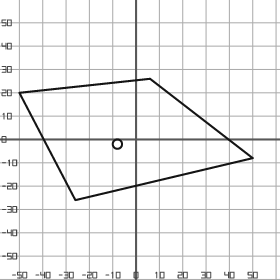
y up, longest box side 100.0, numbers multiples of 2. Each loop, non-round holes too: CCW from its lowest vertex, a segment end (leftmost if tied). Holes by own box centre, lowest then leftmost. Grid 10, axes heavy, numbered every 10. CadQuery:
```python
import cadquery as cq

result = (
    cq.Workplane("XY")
    .moveTo(-26.0, -26.0)
    .lineTo(50.0, -8.0)
    .lineTo(6.0, 26.0)
    .lineTo(-50.0, 20.0)
    .close()
    .moveTo(-8.0, -2.0)
    .circle(2.0)
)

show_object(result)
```